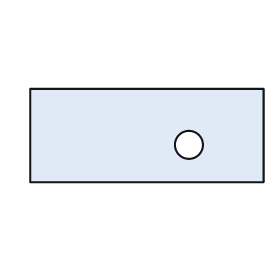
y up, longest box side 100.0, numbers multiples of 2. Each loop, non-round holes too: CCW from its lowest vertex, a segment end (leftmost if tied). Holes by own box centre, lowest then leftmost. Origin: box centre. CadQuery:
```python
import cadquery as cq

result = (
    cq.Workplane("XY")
    .moveTo(-50.0, -20.0)
    .lineTo(50.0, -20.0)
    .lineTo(50.0, 20.0)
    .lineTo(-50.0, 20.0)
    .close()
    .moveTo(18.0, -4.0)
    .circle(6.0)
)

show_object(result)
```